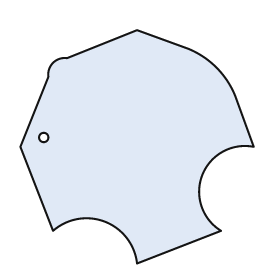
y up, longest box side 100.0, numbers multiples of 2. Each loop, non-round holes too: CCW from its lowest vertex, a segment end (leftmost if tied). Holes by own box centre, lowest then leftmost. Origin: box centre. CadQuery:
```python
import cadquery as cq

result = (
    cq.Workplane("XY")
    .moveTo(0.0, -50.0)
    .lineTo(36.0, -36.0)
    .threePointArc((28.0, -12.0), (50.0, 0.0))
    .lineTo(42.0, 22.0)
    .threePointArc((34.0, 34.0), (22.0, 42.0))
    .lineTo(0.0, 50.0)
    .lineTo(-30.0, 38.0)
    .threePointArc((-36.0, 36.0), (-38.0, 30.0))
    .lineTo(-50.0, 0.0)
    .lineTo(-36.0, -36.0)
    .threePointArc((-14.0, -32.0), (0.0, -50.0))
    .close()
    .moveTo(-40.0, 4.0)
    .circle(2.0)
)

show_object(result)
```